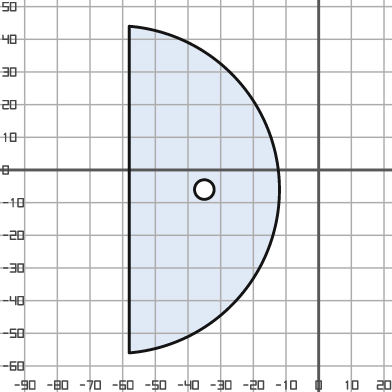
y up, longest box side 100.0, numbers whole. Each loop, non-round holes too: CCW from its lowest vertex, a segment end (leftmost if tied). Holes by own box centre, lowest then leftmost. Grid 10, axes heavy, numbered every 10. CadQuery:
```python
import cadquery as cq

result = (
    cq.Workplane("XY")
    .moveTo(-58.0, -56.0)
    .threePointArc((-12.0, -6.0), (-58.0, 44.0))
    .close()
    .moveTo(-35.0, -6.0)
    .circle(3.0)
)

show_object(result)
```